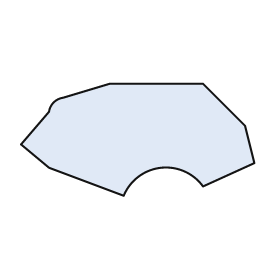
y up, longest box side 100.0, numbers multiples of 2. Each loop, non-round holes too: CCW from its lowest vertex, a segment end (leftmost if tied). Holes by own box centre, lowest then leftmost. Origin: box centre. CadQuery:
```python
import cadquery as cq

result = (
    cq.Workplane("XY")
    .moveTo(-6.0, -24.0)
    .threePointArc((10.0, -12.0), (28.0, -20.0))
    .lineTo(50.0, -10.0)
    .lineTo(46.0, 6.0)
    .lineTo(28.0, 24.0)
    .lineTo(-12.0, 24.0)
    .lineTo(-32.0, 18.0)
    .threePointArc((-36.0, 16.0), (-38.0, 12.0))
    .lineTo(-50.0, -2.0)
    .lineTo(-38.0, -12.0)
    .close()
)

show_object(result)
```